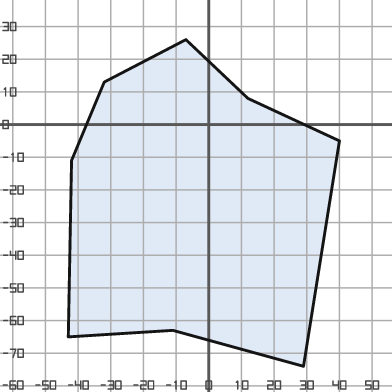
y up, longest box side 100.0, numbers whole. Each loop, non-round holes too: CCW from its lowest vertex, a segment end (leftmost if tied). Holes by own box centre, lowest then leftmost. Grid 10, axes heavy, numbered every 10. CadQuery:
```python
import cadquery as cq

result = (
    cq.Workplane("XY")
    .moveTo(29.0, -74.0)
    .lineTo(40.0, -5.0)
    .lineTo(12.0, 8.0)
    .lineTo(-7.0, 26.0)
    .lineTo(-32.0, 13.0)
    .lineTo(-42.0, -11.0)
    .lineTo(-43.0, -65.0)
    .lineTo(-11.0, -63.0)
    .close()
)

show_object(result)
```